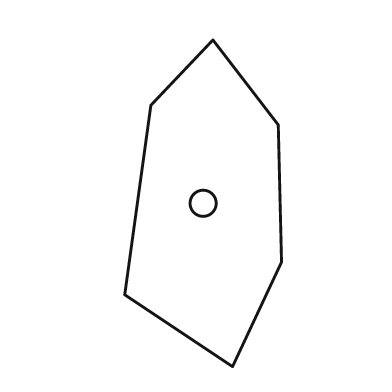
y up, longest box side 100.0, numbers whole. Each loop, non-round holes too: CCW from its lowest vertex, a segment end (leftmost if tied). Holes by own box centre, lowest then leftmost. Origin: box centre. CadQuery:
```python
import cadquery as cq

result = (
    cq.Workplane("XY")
    .moveTo(9.0, -50.0)
    .lineTo(24.0, -18.0)
    .lineTo(23.0, 24.0)
    .lineTo(3.0, 50.0)
    .lineTo(-16.0, 30.0)
    .lineTo(-24.0, -28.0)
    .close()
    .moveTo(0.0, 0.0)
    .circle(4.0)
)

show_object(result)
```